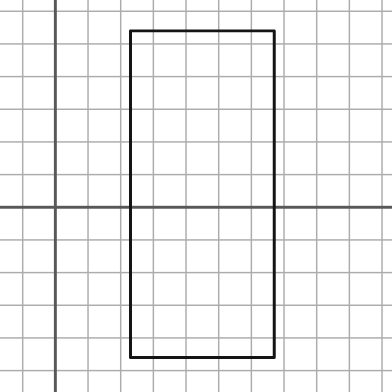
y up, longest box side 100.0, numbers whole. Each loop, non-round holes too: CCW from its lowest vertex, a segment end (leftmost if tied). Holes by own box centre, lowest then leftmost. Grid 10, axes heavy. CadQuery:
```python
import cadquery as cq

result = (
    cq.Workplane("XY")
    .moveTo(23.0, -46.0)
    .lineTo(67.0, -46.0)
    .lineTo(67.0, 54.0)
    .lineTo(23.0, 54.0)
    .close()
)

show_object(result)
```